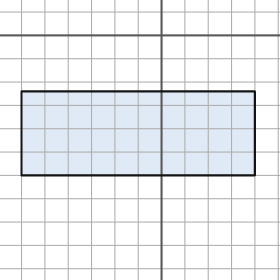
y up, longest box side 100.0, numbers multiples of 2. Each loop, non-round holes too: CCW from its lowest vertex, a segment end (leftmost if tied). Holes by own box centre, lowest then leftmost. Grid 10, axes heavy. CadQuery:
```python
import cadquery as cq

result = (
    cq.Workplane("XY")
    .moveTo(-60.0, -60.0)
    .lineTo(40.0, -60.0)
    .lineTo(40.0, -24.0)
    .lineTo(-60.0, -24.0)
    .close()
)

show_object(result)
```